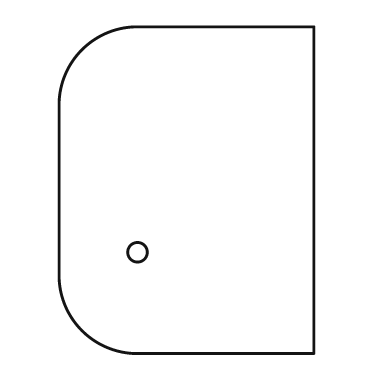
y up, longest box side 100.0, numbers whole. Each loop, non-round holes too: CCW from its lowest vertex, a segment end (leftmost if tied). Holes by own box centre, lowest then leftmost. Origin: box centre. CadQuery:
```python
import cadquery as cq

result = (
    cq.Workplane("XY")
    .moveTo(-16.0, -50.0)
    .lineTo(39.0, -50.0)
    .lineTo(39.0, 50.0)
    .lineTo(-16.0, 50.0)
    .threePointArc((-32.0, 43.0), (-39.0, 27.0))
    .lineTo(-39.0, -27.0)
    .threePointArc((-32.0, -43.0), (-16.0, -50.0))
    .close()
    .moveTo(-15.0, -19.0)
    .circle(3.0)
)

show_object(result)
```